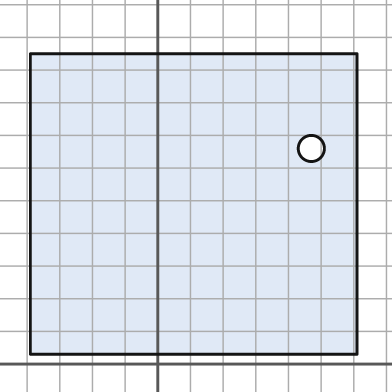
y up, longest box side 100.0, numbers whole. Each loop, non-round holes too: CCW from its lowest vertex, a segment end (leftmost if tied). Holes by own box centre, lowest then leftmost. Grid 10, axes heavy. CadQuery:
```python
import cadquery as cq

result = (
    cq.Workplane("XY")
    .moveTo(-39.0, 3.0)
    .lineTo(61.0, 3.0)
    .lineTo(61.0, 95.0)
    .lineTo(-39.0, 95.0)
    .close()
    .moveTo(47.0, 66.0)
    .circle(4.0)
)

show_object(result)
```